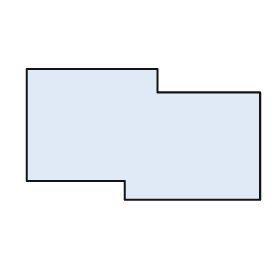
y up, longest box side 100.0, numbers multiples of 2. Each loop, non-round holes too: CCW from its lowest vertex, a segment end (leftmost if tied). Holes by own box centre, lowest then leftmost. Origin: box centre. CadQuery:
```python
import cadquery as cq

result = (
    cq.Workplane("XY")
    .moveTo(-8.0, -28.0)
    .lineTo(50.0, -28.0)
    .lineTo(50.0, 18.0)
    .lineTo(6.0, 18.0)
    .lineTo(6.0, 28.0)
    .lineTo(-50.0, 28.0)
    .lineTo(-50.0, -20.0)
    .lineTo(-8.0, -20.0)
    .close()
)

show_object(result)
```